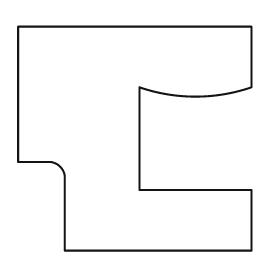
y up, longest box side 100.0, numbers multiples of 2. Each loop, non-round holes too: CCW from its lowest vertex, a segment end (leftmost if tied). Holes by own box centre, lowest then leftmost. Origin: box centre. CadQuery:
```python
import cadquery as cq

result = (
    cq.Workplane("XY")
    .moveTo(-30.0, -48.0)
    .lineTo(50.0, -48.0)
    .lineTo(50.0, -22.0)
    .lineTo(2.0, -22.0)
    .lineTo(2.0, 22.0)
    .threePointArc((26.0, 18.0), (50.0, 22.0))
    .lineTo(50.0, 48.0)
    .lineTo(-50.0, 48.0)
    .lineTo(-50.0, -10.0)
    .lineTo(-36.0, -10.0)
    .threePointArc((-32.0, -12.0), (-30.0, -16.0))
    .close()
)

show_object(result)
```